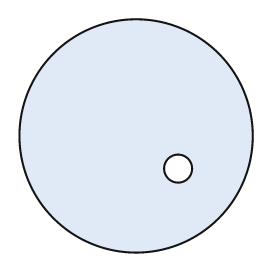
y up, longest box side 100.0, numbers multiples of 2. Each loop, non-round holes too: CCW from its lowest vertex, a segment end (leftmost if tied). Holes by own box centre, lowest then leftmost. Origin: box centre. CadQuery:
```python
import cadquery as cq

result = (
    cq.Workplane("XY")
    .moveTo(0.0, 0.0)
    .circle(50.0)
    .moveTo(18.0, -14.0)
    .circle(6.0)
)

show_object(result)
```